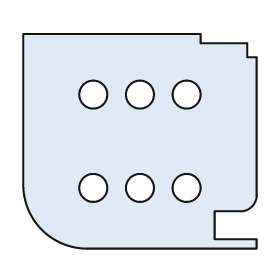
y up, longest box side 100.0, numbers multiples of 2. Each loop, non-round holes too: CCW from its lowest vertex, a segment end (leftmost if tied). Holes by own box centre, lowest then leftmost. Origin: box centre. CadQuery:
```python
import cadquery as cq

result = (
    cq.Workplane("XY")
    .moveTo(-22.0, -46.0)
    .lineTo(50.0, -46.0)
    .lineTo(50.0, -42.0)
    .lineTo(32.0, -42.0)
    .lineTo(32.0, -30.0)
    .lineTo(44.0, -30.0)
    .threePointArc((48.0, -28.0), (50.0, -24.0))
    .lineTo(50.0, 36.0)
    .lineTo(46.0, 36.0)
    .lineTo(46.0, 42.0)
    .lineTo(26.0, 42.0)
    .lineTo(26.0, 46.0)
    .lineTo(-50.0, 46.0)
    .lineTo(-50.0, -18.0)
    .threePointArc((-42.0, -38.0), (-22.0, -46.0))
    .close()
    .moveTo(-20.0, -20.0)
    .circle(6.0)
    .moveTo(0.0, -20.0)
    .circle(6.0)
    .moveTo(20.0, -20.0)
    .circle(6.0)
    .moveTo(-20.0, 20.0)
    .circle(6.0)
    .moveTo(0.0, 20.0)
    .circle(6.0)
    .moveTo(20.0, 20.0)
    .circle(6.0)
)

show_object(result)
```